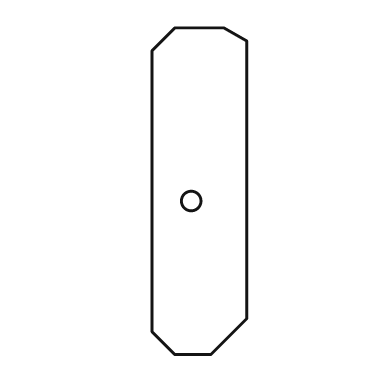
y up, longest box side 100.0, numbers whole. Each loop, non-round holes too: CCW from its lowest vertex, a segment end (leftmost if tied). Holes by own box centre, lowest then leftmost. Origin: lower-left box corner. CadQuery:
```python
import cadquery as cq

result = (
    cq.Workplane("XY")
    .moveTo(7.0, 0.0)
    .lineTo(18.0, 0.0)
    .lineTo(29.0, 11.0)
    .lineTo(29.0, 96.0)
    .lineTo(22.0, 100.0)
    .lineTo(7.0, 100.0)
    .lineTo(0.0, 93.0)
    .lineTo(0.0, 7.0)
    .close()
    .moveTo(12.0, 47.0)
    .circle(3.0)
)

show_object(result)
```